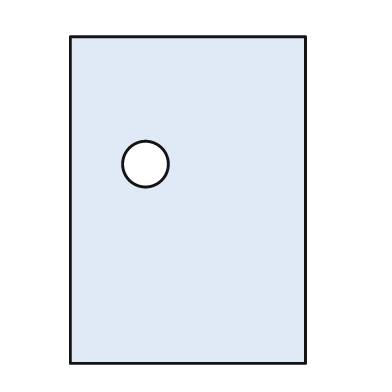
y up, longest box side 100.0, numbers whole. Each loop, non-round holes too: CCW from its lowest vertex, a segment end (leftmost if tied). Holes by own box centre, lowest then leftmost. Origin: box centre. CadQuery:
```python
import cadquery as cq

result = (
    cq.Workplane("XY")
    .moveTo(-36.0, -50.0)
    .lineTo(36.0, -50.0)
    .lineTo(36.0, 50.0)
    .lineTo(-36.0, 50.0)
    .close()
    .moveTo(-13.0, 11.0)
    .circle(7.0)
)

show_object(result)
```